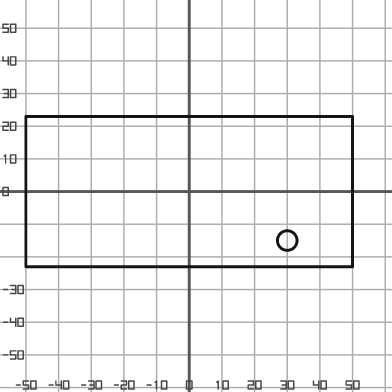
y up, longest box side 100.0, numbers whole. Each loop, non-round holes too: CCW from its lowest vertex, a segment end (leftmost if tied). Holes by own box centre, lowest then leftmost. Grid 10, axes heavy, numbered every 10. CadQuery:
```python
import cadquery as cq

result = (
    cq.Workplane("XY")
    .moveTo(-50.0, -23.0)
    .lineTo(50.0, -23.0)
    .lineTo(50.0, 23.0)
    .lineTo(-50.0, 23.0)
    .close()
    .moveTo(30.0, -15.0)
    .circle(3.0)
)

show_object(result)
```